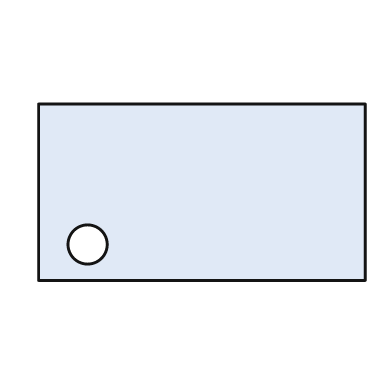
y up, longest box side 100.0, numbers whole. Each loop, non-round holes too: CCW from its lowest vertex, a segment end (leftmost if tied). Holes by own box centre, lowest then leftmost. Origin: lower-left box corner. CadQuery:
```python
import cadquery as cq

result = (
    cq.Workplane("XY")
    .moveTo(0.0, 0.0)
    .lineTo(100.0, 0.0)
    .lineTo(100.0, 54.0)
    .lineTo(0.0, 54.0)
    .close()
    .moveTo(15.0, 11.0)
    .circle(6.0)
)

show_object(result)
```